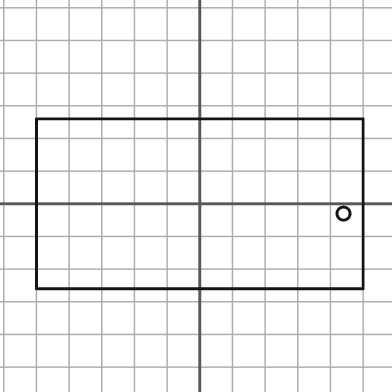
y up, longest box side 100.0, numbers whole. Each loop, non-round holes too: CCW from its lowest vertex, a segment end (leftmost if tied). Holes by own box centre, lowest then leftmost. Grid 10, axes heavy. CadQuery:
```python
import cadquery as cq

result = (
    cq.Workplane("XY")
    .moveTo(-50.0, -26.0)
    .lineTo(50.0, -26.0)
    .lineTo(50.0, 26.0)
    .lineTo(-50.0, 26.0)
    .close()
    .moveTo(44.0, -3.0)
    .circle(2.0)
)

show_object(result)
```